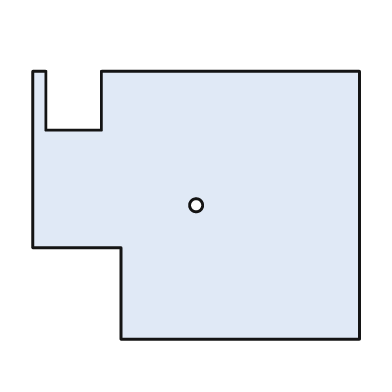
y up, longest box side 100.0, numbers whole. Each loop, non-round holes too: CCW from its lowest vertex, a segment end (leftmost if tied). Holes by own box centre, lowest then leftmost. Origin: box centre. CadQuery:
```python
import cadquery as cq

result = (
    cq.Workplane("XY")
    .moveTo(-23.0, -41.0)
    .lineTo(50.0, -41.0)
    .lineTo(50.0, 41.0)
    .lineTo(-29.0, 41.0)
    .lineTo(-29.0, 23.0)
    .lineTo(-46.0, 23.0)
    .lineTo(-46.0, 41.0)
    .lineTo(-50.0, 41.0)
    .lineTo(-50.0, -13.0)
    .lineTo(-23.0, -13.0)
    .close()
    .moveTo(0.0, 0.0)
    .circle(2.0)
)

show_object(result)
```